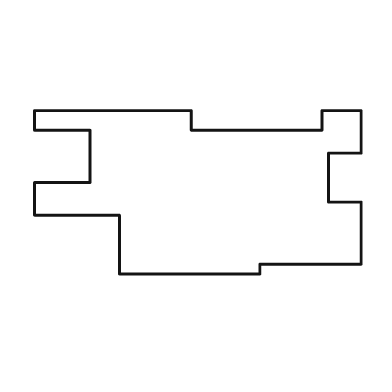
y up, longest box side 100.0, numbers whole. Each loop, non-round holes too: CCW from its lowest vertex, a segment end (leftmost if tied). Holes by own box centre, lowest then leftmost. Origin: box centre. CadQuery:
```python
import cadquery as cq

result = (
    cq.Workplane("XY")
    .moveTo(-24.0, -25.0)
    .lineTo(19.0, -25.0)
    .lineTo(19.0, -22.0)
    .lineTo(50.0, -22.0)
    .lineTo(50.0, -3.0)
    .lineTo(40.0, -3.0)
    .lineTo(40.0, 12.0)
    .lineTo(50.0, 12.0)
    .lineTo(50.0, 25.0)
    .lineTo(38.0, 25.0)
    .lineTo(38.0, 19.0)
    .lineTo(-2.0, 19.0)
    .lineTo(-2.0, 25.0)
    .lineTo(-50.0, 25.0)
    .lineTo(-50.0, 19.0)
    .lineTo(-33.0, 19.0)
    .lineTo(-33.0, 3.0)
    .lineTo(-50.0, 3.0)
    .lineTo(-50.0, -7.0)
    .lineTo(-24.0, -7.0)
    .close()
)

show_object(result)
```